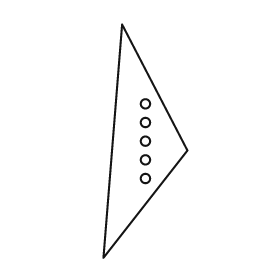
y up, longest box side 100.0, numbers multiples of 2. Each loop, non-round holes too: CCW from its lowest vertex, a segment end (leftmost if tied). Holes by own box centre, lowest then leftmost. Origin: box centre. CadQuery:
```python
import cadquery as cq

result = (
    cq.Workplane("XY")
    .moveTo(-18.0, -50.0)
    .lineTo(18.0, -4.0)
    .lineTo(-10.0, 50.0)
    .close()
    .moveTo(0.0, -16.0)
    .circle(2.0)
    .moveTo(0.0, -8.0)
    .circle(2.0)
    .moveTo(0.0, 0.0)
    .circle(2.0)
    .moveTo(0.0, 8.0)
    .circle(2.0)
    .moveTo(0.0, 16.0)
    .circle(2.0)
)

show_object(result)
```